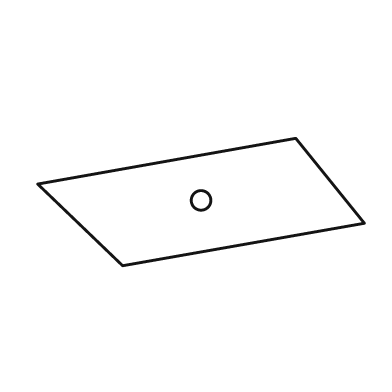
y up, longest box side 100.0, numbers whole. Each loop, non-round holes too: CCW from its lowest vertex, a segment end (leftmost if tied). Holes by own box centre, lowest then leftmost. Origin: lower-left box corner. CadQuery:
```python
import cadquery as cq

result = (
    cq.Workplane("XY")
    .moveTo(26.0, 0.0)
    .lineTo(100.0, 13.0)
    .lineTo(79.0, 39.0)
    .lineTo(0.0, 25.0)
    .close()
    .moveTo(50.0, 20.0)
    .circle(3.0)
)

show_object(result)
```